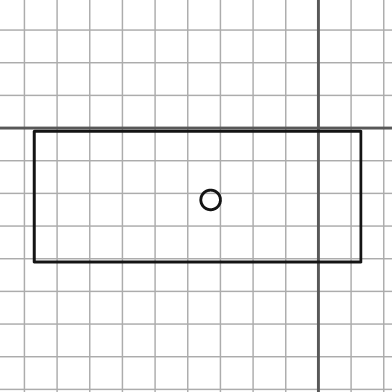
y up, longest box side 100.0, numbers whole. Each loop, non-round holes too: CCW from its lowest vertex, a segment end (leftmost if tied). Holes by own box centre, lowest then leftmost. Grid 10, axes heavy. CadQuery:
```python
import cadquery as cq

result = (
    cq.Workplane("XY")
    .moveTo(-87.0, -41.0)
    .lineTo(13.0, -41.0)
    .lineTo(13.0, -1.0)
    .lineTo(-87.0, -1.0)
    .close()
    .moveTo(-33.0, -22.0)
    .circle(3.0)
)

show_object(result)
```